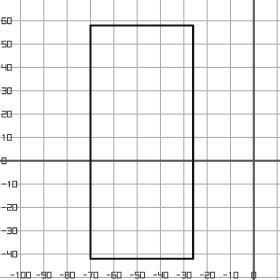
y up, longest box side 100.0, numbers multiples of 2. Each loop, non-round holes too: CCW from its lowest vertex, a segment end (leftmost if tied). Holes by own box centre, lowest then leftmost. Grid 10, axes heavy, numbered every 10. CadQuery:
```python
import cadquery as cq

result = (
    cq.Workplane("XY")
    .moveTo(-70.0, -42.0)
    .lineTo(-26.0, -42.0)
    .lineTo(-26.0, 58.0)
    .lineTo(-70.0, 58.0)
    .close()
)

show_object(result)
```